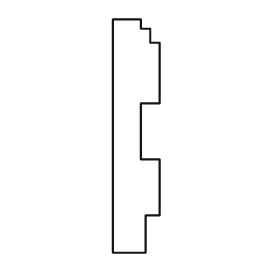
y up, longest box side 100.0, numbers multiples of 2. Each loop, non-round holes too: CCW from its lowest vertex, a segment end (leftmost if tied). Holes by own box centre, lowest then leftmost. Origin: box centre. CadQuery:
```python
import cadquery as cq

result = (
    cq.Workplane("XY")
    .moveTo(-10.0, -50.0)
    .lineTo(4.0, -50.0)
    .lineTo(4.0, -34.0)
    .lineTo(10.0, -34.0)
    .lineTo(10.0, -10.0)
    .lineTo(2.0, -10.0)
    .lineTo(2.0, 14.0)
    .lineTo(10.0, 14.0)
    .lineTo(10.0, 40.0)
    .lineTo(6.0, 40.0)
    .lineTo(6.0, 46.0)
    .lineTo(2.0, 46.0)
    .lineTo(2.0, 50.0)
    .lineTo(-10.0, 50.0)
    .close()
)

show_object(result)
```